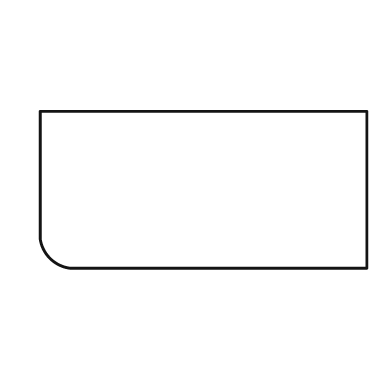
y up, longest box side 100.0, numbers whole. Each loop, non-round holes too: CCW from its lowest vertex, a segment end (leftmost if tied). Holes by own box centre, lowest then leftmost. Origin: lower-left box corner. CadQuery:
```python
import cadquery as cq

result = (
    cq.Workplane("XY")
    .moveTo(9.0, 0.0)
    .lineTo(100.0, 0.0)
    .lineTo(100.0, 48.0)
    .lineTo(0.0, 48.0)
    .lineTo(0.0, 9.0)
    .threePointArc((3.0, 3.0), (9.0, 0.0))
    .close()
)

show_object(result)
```